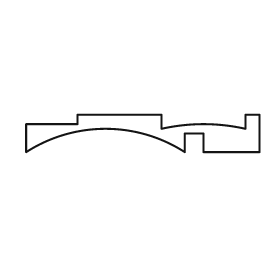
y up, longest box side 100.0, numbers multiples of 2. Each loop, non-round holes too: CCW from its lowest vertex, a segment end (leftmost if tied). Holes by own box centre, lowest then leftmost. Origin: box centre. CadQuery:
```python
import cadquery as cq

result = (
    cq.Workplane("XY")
    .moveTo(-50.0, -8.0)
    .threePointArc((-16.0, 2.0), (18.0, -8.0))
    .lineTo(18.0, 0.0)
    .lineTo(26.0, 0.0)
    .lineTo(26.0, -8.0)
    .lineTo(50.0, -8.0)
    .lineTo(50.0, 8.0)
    .lineTo(44.0, 8.0)
    .lineTo(44.0, 2.0)
    .threePointArc((26.0, 4.0), (8.0, 2.0))
    .lineTo(8.0, 8.0)
    .lineTo(-28.0, 8.0)
    .lineTo(-28.0, 4.0)
    .lineTo(-50.0, 4.0)
    .close()
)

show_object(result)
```